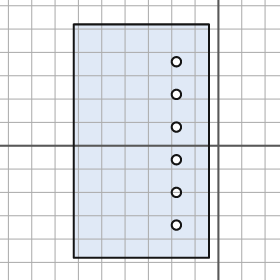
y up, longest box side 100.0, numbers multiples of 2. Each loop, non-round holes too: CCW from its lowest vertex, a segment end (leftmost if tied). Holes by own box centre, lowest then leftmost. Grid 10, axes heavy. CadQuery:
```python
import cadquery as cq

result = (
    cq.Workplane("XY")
    .moveTo(-62.0, -48.0)
    .lineTo(-4.0, -48.0)
    .lineTo(-4.0, 52.0)
    .lineTo(-62.0, 52.0)
    .close()
    .moveTo(-18.0, -34.0)
    .circle(2.0)
    .moveTo(-18.0, -20.0)
    .circle(2.0)
    .moveTo(-18.0, -6.0)
    .circle(2.0)
    .moveTo(-18.0, 8.0)
    .circle(2.0)
    .moveTo(-18.0, 22.0)
    .circle(2.0)
    .moveTo(-18.0, 36.0)
    .circle(2.0)
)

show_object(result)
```